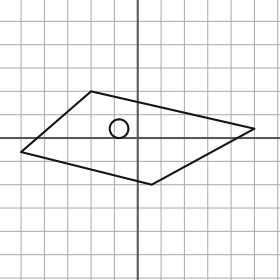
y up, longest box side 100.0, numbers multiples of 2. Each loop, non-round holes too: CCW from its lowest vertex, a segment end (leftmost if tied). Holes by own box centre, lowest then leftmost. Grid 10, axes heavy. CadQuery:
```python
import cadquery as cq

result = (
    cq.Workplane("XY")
    .moveTo(6.0, -20.0)
    .lineTo(50.0, 4.0)
    .lineTo(-20.0, 20.0)
    .lineTo(-50.0, -6.0)
    .close()
    .moveTo(-8.0, 4.0)
    .circle(4.0)
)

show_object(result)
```